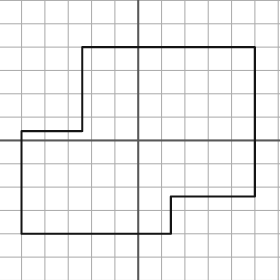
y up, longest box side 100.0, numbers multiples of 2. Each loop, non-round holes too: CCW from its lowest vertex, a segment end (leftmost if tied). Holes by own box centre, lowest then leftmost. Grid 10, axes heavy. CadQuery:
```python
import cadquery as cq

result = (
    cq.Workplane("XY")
    .moveTo(-50.0, -40.0)
    .lineTo(14.0, -40.0)
    .lineTo(14.0, -24.0)
    .lineTo(50.0, -24.0)
    .lineTo(50.0, 40.0)
    .lineTo(-24.0, 40.0)
    .lineTo(-24.0, 4.0)
    .lineTo(-50.0, 4.0)
    .close()
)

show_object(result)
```